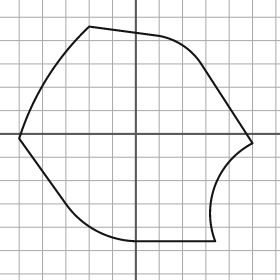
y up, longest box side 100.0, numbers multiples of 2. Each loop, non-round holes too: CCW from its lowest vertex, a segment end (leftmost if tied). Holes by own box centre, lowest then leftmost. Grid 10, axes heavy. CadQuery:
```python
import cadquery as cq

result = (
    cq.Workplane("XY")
    .moveTo(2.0, -46.0)
    .lineTo(34.0, -46.0)
    .threePointArc((34.0, -22.0), (50.0, -4.0))
    .lineTo(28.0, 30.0)
    .threePointArc((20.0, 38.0), (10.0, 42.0))
    .lineTo(-20.0, 46.0)
    .threePointArc((-38.0, 24.0), (-50.0, -2.0))
    .lineTo(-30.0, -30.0)
    .threePointArc((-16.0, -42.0), (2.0, -46.0))
    .close()
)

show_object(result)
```